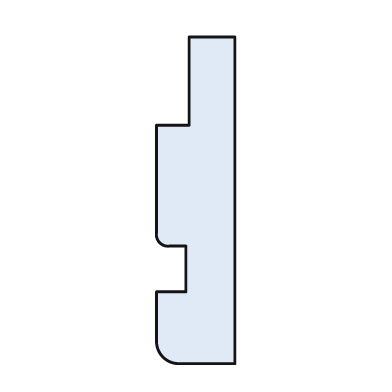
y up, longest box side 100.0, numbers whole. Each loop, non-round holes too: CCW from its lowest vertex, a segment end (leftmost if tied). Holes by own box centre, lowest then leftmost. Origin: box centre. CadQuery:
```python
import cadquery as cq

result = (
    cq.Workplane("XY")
    .moveTo(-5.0, -50.0)
    .lineTo(12.0, -50.0)
    .lineTo(12.0, 50.0)
    .lineTo(-2.0, 50.0)
    .lineTo(-2.0, 23.0)
    .lineTo(-12.0, 23.0)
    .lineTo(-12.0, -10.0)
    .threePointArc((-11.0, -13.0), (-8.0, -14.0))
    .lineTo(-3.0, -14.0)
    .lineTo(-3.0, -28.0)
    .lineTo(-12.0, -28.0)
    .lineTo(-12.0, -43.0)
    .threePointArc((-10.0, -48.0), (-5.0, -50.0))
    .close()
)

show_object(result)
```